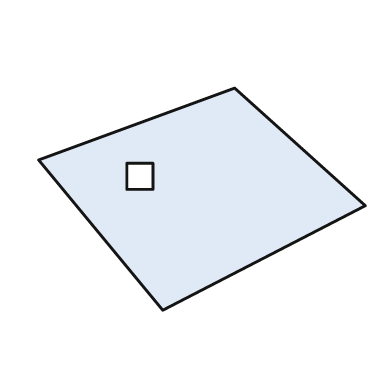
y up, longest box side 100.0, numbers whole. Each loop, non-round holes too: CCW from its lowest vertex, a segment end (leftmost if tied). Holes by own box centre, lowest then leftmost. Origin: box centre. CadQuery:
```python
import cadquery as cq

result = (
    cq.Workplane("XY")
    .moveTo(-12.0, -34.0)
    .lineTo(50.0, -2.0)
    .lineTo(10.0, 34.0)
    .lineTo(-50.0, 12.0)
    .close()
    .moveTo(-23.0, 3.0)
    .lineTo(-15.0, 3.0)
    .lineTo(-15.0, 11.0)
    .lineTo(-23.0, 11.0)
    .close()
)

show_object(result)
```